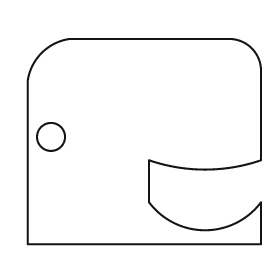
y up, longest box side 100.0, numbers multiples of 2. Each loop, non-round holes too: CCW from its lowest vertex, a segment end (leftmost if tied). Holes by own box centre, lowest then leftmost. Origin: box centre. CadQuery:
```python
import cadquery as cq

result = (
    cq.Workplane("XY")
    .moveTo(-50.0, -44.0)
    .lineTo(50.0, -44.0)
    .lineTo(50.0, -26.0)
    .threePointArc((26.0, -38.0), (2.0, -26.0))
    .lineTo(2.0, -8.0)
    .threePointArc((26.0, -12.0), (50.0, -8.0))
    .lineTo(50.0, 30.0)
    .threePointArc((46.0, 40.0), (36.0, 44.0))
    .lineTo(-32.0, 44.0)
    .threePointArc((-44.0, 38.0), (-50.0, 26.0))
    .close()
    .moveTo(-40.0, 2.0)
    .circle(6.0)
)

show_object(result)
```